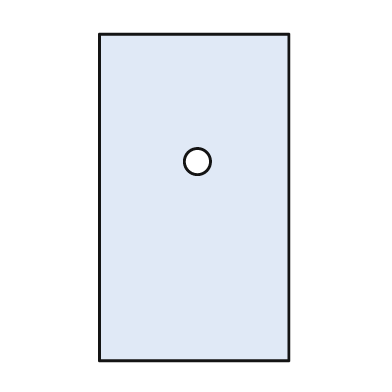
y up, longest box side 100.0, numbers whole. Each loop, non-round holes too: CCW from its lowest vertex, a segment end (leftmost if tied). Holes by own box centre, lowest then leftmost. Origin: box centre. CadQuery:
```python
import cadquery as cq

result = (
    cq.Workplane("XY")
    .moveTo(-29.0, -50.0)
    .lineTo(29.0, -50.0)
    .lineTo(29.0, 50.0)
    .lineTo(-29.0, 50.0)
    .close()
    .moveTo(1.0, 11.0)
    .circle(4.0)
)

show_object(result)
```